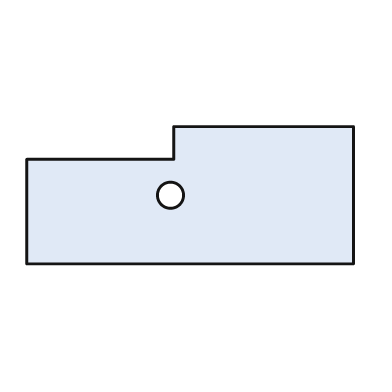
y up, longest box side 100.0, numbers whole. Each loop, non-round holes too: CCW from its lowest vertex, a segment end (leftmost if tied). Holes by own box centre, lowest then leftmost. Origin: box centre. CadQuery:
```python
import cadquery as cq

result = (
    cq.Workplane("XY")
    .moveTo(-50.0, -21.0)
    .lineTo(50.0, -21.0)
    .lineTo(50.0, 21.0)
    .lineTo(-5.0, 21.0)
    .lineTo(-5.0, 11.0)
    .lineTo(-50.0, 11.0)
    .close()
    .moveTo(-6.0, 0.0)
    .circle(4.0)
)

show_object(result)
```